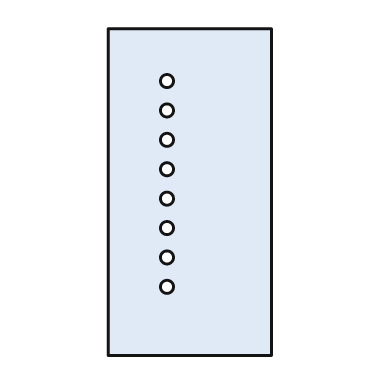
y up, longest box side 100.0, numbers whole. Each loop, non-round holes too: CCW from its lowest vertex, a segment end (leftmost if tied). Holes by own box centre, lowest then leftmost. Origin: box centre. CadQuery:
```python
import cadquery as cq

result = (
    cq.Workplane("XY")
    .moveTo(-25.0, -50.0)
    .lineTo(25.0, -50.0)
    .lineTo(25.0, 50.0)
    .lineTo(-25.0, 50.0)
    .close()
    .moveTo(-7.0, -29.0)
    .circle(2.0)
    .moveTo(-7.0, -20.0)
    .circle(2.0)
    .moveTo(-7.0, -11.0)
    .circle(2.0)
    .moveTo(-7.0, -2.0)
    .circle(2.0)
    .moveTo(-7.0, 7.0)
    .circle(2.0)
    .moveTo(-7.0, 16.0)
    .circle(2.0)
    .moveTo(-7.0, 25.0)
    .circle(2.0)
    .moveTo(-7.0, 34.0)
    .circle(2.0)
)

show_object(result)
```